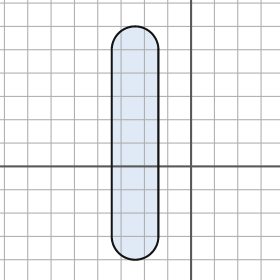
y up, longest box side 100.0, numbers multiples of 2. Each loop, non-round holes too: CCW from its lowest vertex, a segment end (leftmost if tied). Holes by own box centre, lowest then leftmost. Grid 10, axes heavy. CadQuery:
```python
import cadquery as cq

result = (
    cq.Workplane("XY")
    .moveTo(-34.0, -30.0)
    .threePointArc((-24.0, -40.0), (-14.0, -30.0))
    .lineTo(-14.0, 50.0)
    .threePointArc((-24.0, 60.0), (-34.0, 50.0))
    .close()
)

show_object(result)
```